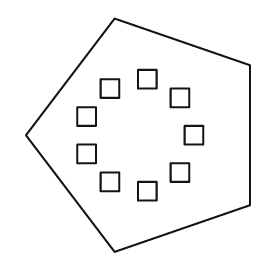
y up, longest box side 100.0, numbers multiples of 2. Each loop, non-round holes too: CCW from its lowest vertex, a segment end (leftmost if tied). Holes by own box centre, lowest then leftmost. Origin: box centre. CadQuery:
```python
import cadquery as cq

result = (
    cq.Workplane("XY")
    .moveTo(-10.0, -50.0)
    .lineTo(48.0, -30.0)
    .lineTo(48.0, 30.0)
    .lineTo(-10.0, 50.0)
    .lineTo(-48.0, 0.0)
    .close()
    .moveTo(0.0, -28.0)
    .lineTo(8.0, -28.0)
    .lineTo(8.0, -20.0)
    .lineTo(0.0, -20.0)
    .close()
    .moveTo(-16.0, -24.0)
    .lineTo(-8.0, -24.0)
    .lineTo(-8.0, -16.0)
    .lineTo(-16.0, -16.0)
    .close()
    .moveTo(14.0, -20.0)
    .lineTo(22.0, -20.0)
    .lineTo(22.0, -12.0)
    .lineTo(14.0, -12.0)
    .close()
    .moveTo(-26.0, -12.0)
    .lineTo(-18.0, -12.0)
    .lineTo(-18.0, -4.0)
    .lineTo(-26.0, -4.0)
    .close()
    .moveTo(20.0, -4.0)
    .lineTo(28.0, -4.0)
    .lineTo(28.0, 4.0)
    .lineTo(20.0, 4.0)
    .close()
    .moveTo(-26.0, 4.0)
    .lineTo(-18.0, 4.0)
    .lineTo(-18.0, 12.0)
    .lineTo(-26.0, 12.0)
    .close()
    .moveTo(14.0, 12.0)
    .lineTo(22.0, 12.0)
    .lineTo(22.0, 20.0)
    .lineTo(14.0, 20.0)
    .close()
    .moveTo(-16.0, 16.0)
    .lineTo(-8.0, 16.0)
    .lineTo(-8.0, 24.0)
    .lineTo(-16.0, 24.0)
    .close()
    .moveTo(0.0, 20.0)
    .lineTo(8.0, 20.0)
    .lineTo(8.0, 28.0)
    .lineTo(0.0, 28.0)
    .close()
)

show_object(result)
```